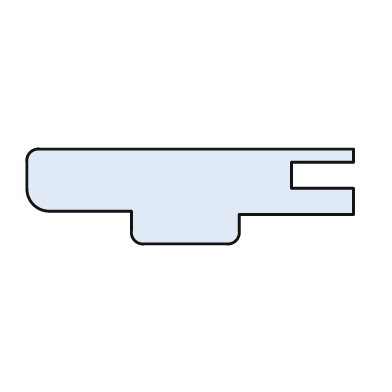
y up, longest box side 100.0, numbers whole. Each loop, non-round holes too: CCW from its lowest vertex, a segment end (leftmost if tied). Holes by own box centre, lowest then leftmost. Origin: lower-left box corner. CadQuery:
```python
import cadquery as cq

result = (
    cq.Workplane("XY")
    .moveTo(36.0, 0.0)
    .lineTo(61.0, 0.0)
    .threePointArc((64.0, 1.0), (65.0, 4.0))
    .lineTo(65.0, 9.0)
    .lineTo(100.0, 9.0)
    .lineTo(100.0, 17.0)
    .lineTo(81.0, 17.0)
    .lineTo(81.0, 25.0)
    .lineTo(100.0, 25.0)
    .lineTo(100.0, 29.0)
    .lineTo(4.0, 29.0)
    .threePointArc((1.0, 28.0), (0.0, 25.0))
    .lineTo(0.0, 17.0)
    .threePointArc((2.0, 12.0), (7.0, 10.0))
    .lineTo(32.0, 10.0)
    .lineTo(32.0, 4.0)
    .threePointArc((33.0, 1.0), (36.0, 0.0))
    .close()
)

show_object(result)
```